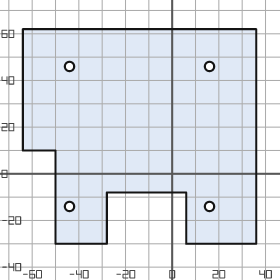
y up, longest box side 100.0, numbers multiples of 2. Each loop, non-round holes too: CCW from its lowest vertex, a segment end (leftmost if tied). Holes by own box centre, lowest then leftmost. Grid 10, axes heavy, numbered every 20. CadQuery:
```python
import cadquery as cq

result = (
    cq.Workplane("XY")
    .moveTo(-50.0, -30.0)
    .lineTo(-28.0, -30.0)
    .lineTo(-28.0, -8.0)
    .lineTo(6.0, -8.0)
    .lineTo(6.0, -30.0)
    .lineTo(36.0, -30.0)
    .lineTo(36.0, 62.0)
    .lineTo(-64.0, 62.0)
    .lineTo(-64.0, 10.0)
    .lineTo(-50.0, 10.0)
    .close()
    .moveTo(-44.0, -14.0)
    .circle(2.0)
    .moveTo(16.0, -14.0)
    .circle(2.0)
    .moveTo(-44.0, 46.0)
    .circle(2.0)
    .moveTo(16.0, 46.0)
    .circle(2.0)
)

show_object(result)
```